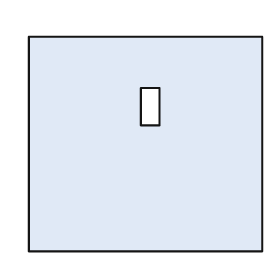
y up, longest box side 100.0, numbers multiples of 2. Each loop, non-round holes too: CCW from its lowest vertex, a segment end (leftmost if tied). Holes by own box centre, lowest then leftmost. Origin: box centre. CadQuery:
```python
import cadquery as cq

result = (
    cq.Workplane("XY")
    .moveTo(-50.0, -46.0)
    .lineTo(50.0, -46.0)
    .lineTo(50.0, 46.0)
    .lineTo(-50.0, 46.0)
    .close()
    .moveTo(-2.0, 8.0)
    .lineTo(6.0, 8.0)
    .lineTo(6.0, 24.0)
    .lineTo(-2.0, 24.0)
    .close()
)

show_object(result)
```